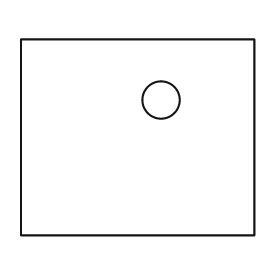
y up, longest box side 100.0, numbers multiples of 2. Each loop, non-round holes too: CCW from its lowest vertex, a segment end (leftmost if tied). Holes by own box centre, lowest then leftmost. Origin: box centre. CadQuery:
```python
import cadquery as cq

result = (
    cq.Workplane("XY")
    .moveTo(-50.0, -42.0)
    .lineTo(50.0, -42.0)
    .lineTo(50.0, 42.0)
    .lineTo(-50.0, 42.0)
    .close()
    .moveTo(10.0, 16.0)
    .circle(8.0)
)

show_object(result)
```